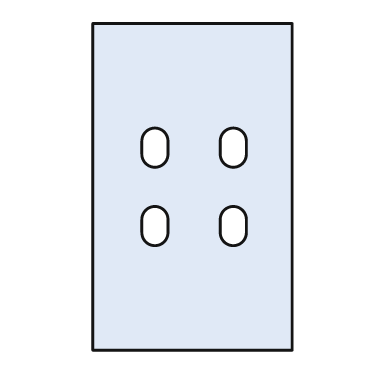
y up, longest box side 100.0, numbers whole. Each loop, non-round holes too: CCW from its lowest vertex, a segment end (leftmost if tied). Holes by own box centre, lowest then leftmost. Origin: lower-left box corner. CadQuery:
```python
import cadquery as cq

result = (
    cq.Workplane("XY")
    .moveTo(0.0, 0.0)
    .lineTo(61.0, 0.0)
    .lineTo(61.0, 100.0)
    .lineTo(0.0, 100.0)
    .close()
    .moveTo(15.0, 36.0)
    .threePointArc((19.0, 32.0), (23.0, 36.0))
    .lineTo(23.0, 40.0)
    .threePointArc((19.0, 44.0), (15.0, 40.0))
    .close()
    .moveTo(39.0, 36.0)
    .threePointArc((43.0, 32.0), (47.0, 36.0))
    .lineTo(47.0, 40.0)
    .threePointArc((43.0, 44.0), (39.0, 40.0))
    .close()
    .moveTo(15.0, 60.0)
    .threePointArc((19.0, 56.0), (23.0, 60.0))
    .lineTo(23.0, 64.0)
    .threePointArc((19.0, 68.0), (15.0, 64.0))
    .close()
    .moveTo(39.0, 60.0)
    .threePointArc((43.0, 56.0), (47.0, 60.0))
    .lineTo(47.0, 64.0)
    .threePointArc((43.0, 68.0), (39.0, 64.0))
    .close()
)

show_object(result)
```